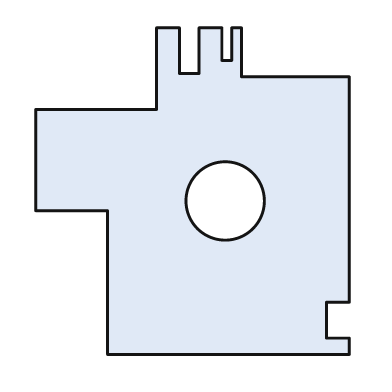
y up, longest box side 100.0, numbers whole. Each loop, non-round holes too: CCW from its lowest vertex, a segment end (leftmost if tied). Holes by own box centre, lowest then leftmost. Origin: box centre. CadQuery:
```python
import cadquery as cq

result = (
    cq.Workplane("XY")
    .moveTo(-26.0, -50.0)
    .lineTo(48.0, -50.0)
    .lineTo(48.0, -45.0)
    .lineTo(41.0, -45.0)
    .lineTo(41.0, -34.0)
    .lineTo(48.0, -34.0)
    .lineTo(48.0, 35.0)
    .lineTo(15.0, 35.0)
    .lineTo(15.0, 50.0)
    .lineTo(12.0, 50.0)
    .lineTo(12.0, 40.0)
    .lineTo(9.0, 40.0)
    .lineTo(9.0, 50.0)
    .lineTo(2.0, 50.0)
    .lineTo(2.0, 36.0)
    .lineTo(-4.0, 36.0)
    .lineTo(-4.0, 50.0)
    .lineTo(-11.0, 50.0)
    .lineTo(-11.0, 25.0)
    .lineTo(-48.0, 25.0)
    .lineTo(-48.0, -6.0)
    .lineTo(-26.0, -6.0)
    .close()
    .moveTo(10.0, -3.0)
    .circle(12.0)
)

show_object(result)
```